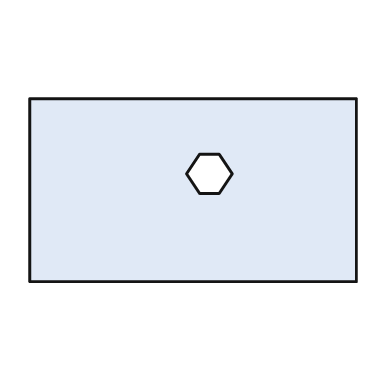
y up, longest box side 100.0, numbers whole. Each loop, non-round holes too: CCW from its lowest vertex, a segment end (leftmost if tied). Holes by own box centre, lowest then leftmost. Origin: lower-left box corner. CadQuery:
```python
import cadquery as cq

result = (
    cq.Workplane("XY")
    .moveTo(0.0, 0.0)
    .lineTo(100.0, 0.0)
    .lineTo(100.0, 56.0)
    .lineTo(0.0, 56.0)
    .close()
    .moveTo(52.0, 27.0)
    .lineTo(58.0, 27.0)
    .lineTo(62.0, 33.0)
    .lineTo(58.0, 39.0)
    .lineTo(52.0, 39.0)
    .lineTo(48.0, 33.0)
    .close()
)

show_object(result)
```